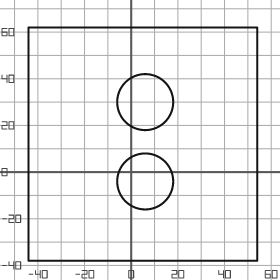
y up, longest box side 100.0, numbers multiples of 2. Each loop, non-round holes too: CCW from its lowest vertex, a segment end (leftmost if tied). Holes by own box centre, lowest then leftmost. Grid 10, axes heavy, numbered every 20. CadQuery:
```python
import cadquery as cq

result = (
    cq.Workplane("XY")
    .moveTo(-44.0, -38.0)
    .lineTo(54.0, -38.0)
    .lineTo(54.0, 62.0)
    .lineTo(-44.0, 62.0)
    .close()
    .moveTo(6.0, -4.0)
    .circle(12.0)
    .moveTo(6.0, 30.0)
    .circle(12.0)
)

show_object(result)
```